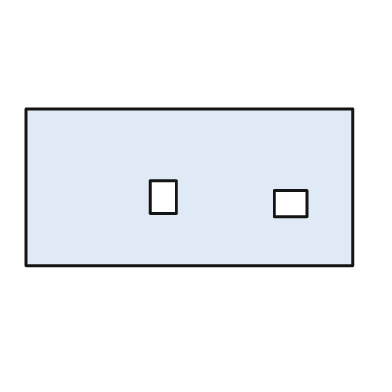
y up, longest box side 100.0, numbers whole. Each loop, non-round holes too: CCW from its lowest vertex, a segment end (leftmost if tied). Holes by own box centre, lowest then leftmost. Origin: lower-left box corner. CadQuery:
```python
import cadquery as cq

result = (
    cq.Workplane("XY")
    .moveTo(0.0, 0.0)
    .lineTo(100.0, 0.0)
    .lineTo(100.0, 48.0)
    .lineTo(0.0, 48.0)
    .close()
    .moveTo(76.0, 15.0)
    .lineTo(86.0, 15.0)
    .lineTo(86.0, 23.0)
    .lineTo(76.0, 23.0)
    .close()
    .moveTo(38.0, 16.0)
    .lineTo(46.0, 16.0)
    .lineTo(46.0, 26.0)
    .lineTo(38.0, 26.0)
    .close()
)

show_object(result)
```